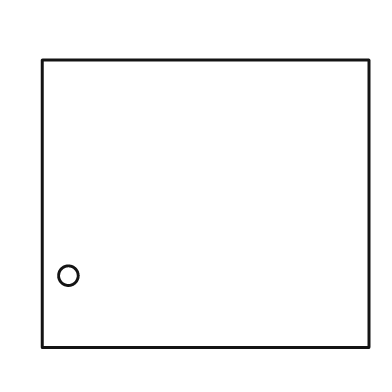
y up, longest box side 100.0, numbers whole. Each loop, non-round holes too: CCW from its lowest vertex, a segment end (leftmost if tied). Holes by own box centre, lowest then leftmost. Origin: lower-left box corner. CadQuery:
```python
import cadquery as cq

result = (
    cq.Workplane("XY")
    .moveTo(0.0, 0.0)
    .lineTo(100.0, 0.0)
    .lineTo(100.0, 88.0)
    .lineTo(0.0, 88.0)
    .close()
    .moveTo(8.0, 22.0)
    .circle(3.0)
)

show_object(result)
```